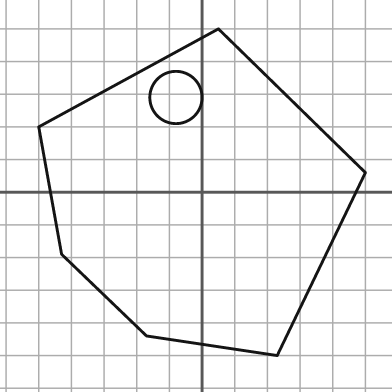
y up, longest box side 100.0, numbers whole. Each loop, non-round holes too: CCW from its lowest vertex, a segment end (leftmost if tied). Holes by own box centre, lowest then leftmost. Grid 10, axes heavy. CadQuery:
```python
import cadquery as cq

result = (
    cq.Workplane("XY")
    .moveTo(23.0, -50.0)
    .lineTo(50.0, 6.0)
    .lineTo(5.0, 50.0)
    .lineTo(-50.0, 20.0)
    .lineTo(-43.0, -19.0)
    .lineTo(-17.0, -44.0)
    .close()
    .moveTo(-8.0, 29.0)
    .circle(8.0)
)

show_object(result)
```